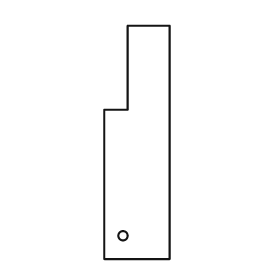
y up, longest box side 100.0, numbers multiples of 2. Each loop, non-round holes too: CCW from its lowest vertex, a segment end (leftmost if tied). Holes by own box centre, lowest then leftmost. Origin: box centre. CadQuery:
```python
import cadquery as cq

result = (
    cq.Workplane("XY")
    .moveTo(-14.0, -50.0)
    .lineTo(14.0, -50.0)
    .lineTo(14.0, 50.0)
    .lineTo(-4.0, 50.0)
    .lineTo(-4.0, 14.0)
    .lineTo(-14.0, 14.0)
    .close()
    .moveTo(-6.0, -40.0)
    .circle(2.0)
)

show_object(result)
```